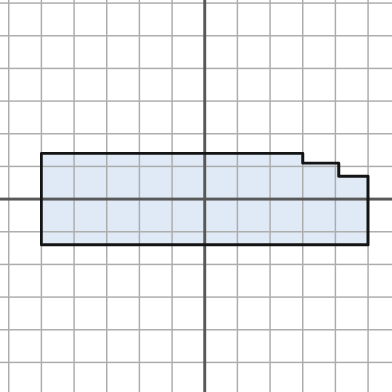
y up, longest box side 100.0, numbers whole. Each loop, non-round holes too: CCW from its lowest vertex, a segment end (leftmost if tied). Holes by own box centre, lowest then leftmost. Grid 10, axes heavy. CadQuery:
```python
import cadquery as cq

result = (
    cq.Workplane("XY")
    .moveTo(-50.0, -14.0)
    .lineTo(50.0, -14.0)
    .lineTo(50.0, 7.0)
    .lineTo(41.0, 7.0)
    .lineTo(41.0, 11.0)
    .lineTo(30.0, 11.0)
    .lineTo(30.0, 14.0)
    .lineTo(-50.0, 14.0)
    .close()
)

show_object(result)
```